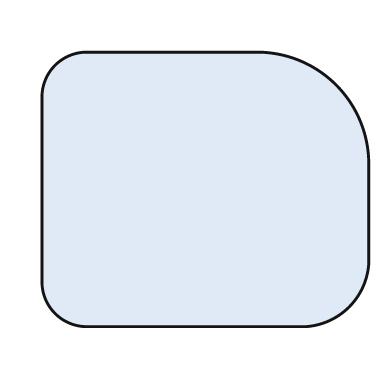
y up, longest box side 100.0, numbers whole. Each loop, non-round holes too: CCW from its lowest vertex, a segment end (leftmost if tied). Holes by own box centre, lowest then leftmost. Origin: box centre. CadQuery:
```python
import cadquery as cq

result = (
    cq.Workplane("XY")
    .moveTo(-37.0, -42.0)
    .lineTo(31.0, -42.0)
    .threePointArc((44.0, -36.0), (50.0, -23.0))
    .lineTo(50.0, 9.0)
    .threePointArc((40.0, 32.0), (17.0, 42.0))
    .lineTo(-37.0, 42.0)
    .threePointArc((-46.0, 38.0), (-50.0, 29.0))
    .lineTo(-50.0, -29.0)
    .threePointArc((-46.0, -38.0), (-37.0, -42.0))
    .close()
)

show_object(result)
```